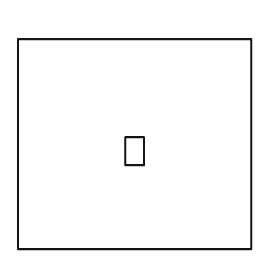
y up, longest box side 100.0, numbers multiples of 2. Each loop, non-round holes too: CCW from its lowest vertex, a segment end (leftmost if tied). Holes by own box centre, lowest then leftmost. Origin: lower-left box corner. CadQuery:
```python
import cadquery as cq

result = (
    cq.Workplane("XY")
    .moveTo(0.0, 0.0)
    .lineTo(100.0, 0.0)
    .lineTo(100.0, 90.0)
    .lineTo(0.0, 90.0)
    .close()
    .moveTo(46.0, 36.0)
    .lineTo(54.0, 36.0)
    .lineTo(54.0, 48.0)
    .lineTo(46.0, 48.0)
    .close()
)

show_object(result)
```